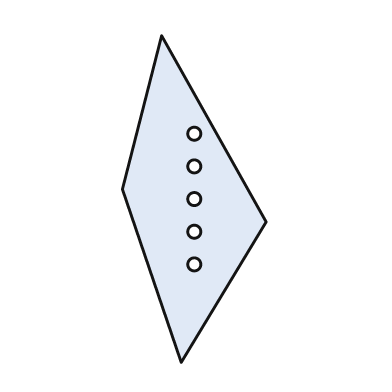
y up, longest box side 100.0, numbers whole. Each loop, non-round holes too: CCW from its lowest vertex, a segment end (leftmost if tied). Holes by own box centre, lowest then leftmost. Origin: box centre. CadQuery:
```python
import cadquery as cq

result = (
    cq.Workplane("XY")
    .moveTo(-4.0, -50.0)
    .lineTo(22.0, -7.0)
    .lineTo(-10.0, 50.0)
    .lineTo(-22.0, 3.0)
    .close()
    .moveTo(0.0, -20.0)
    .circle(2.0)
    .moveTo(0.0, -10.0)
    .circle(2.0)
    .moveTo(0.0, 0.0)
    .circle(2.0)
    .moveTo(0.0, 10.0)
    .circle(2.0)
    .moveTo(0.0, 20.0)
    .circle(2.0)
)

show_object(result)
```